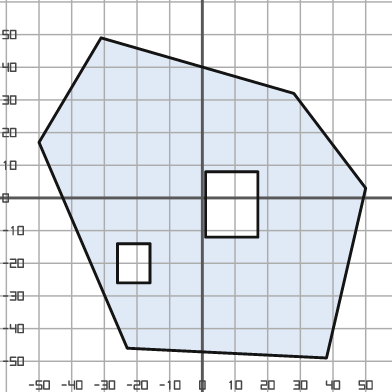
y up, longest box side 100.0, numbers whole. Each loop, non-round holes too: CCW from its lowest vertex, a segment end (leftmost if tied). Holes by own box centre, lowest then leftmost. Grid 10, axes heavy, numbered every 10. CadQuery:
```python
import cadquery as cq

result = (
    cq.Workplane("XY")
    .moveTo(38.0, -49.0)
    .lineTo(50.0, 3.0)
    .lineTo(28.0, 32.0)
    .lineTo(-31.0, 49.0)
    .lineTo(-50.0, 17.0)
    .lineTo(-23.0, -46.0)
    .close()
    .moveTo(-26.0, -26.0)
    .lineTo(-16.0, -26.0)
    .lineTo(-16.0, -14.0)
    .lineTo(-26.0, -14.0)
    .close()
    .moveTo(1.0, -12.0)
    .lineTo(17.0, -12.0)
    .lineTo(17.0, 8.0)
    .lineTo(1.0, 8.0)
    .close()
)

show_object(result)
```